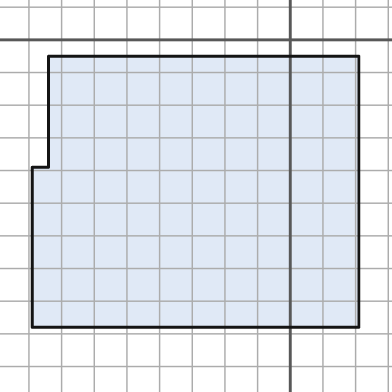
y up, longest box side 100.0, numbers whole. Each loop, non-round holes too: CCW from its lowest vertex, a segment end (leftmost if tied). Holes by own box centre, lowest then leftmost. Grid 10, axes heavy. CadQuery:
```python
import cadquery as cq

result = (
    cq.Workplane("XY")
    .moveTo(-79.0, -88.0)
    .lineTo(21.0, -88.0)
    .lineTo(21.0, -5.0)
    .lineTo(-74.0, -5.0)
    .lineTo(-74.0, -39.0)
    .lineTo(-79.0, -39.0)
    .close()
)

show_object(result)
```